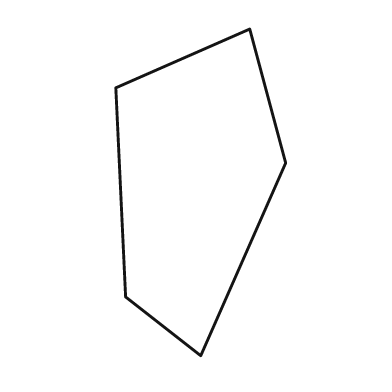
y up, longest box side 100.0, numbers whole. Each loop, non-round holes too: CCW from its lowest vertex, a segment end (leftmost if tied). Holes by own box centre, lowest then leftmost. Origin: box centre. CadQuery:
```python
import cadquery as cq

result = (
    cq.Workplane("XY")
    .moveTo(0.0, -50.0)
    .lineTo(26.0, 9.0)
    .lineTo(15.0, 50.0)
    .lineTo(-26.0, 32.0)
    .lineTo(-23.0, -32.0)
    .close()
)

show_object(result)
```